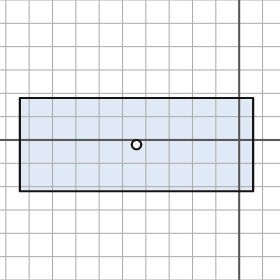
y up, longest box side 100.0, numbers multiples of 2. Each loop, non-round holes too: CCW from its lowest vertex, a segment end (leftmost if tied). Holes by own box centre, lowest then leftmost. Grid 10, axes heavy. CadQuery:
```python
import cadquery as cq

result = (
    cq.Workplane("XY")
    .moveTo(-94.0, -22.0)
    .lineTo(6.0, -22.0)
    .lineTo(6.0, 18.0)
    .lineTo(-94.0, 18.0)
    .close()
    .moveTo(-44.0, -2.0)
    .circle(2.0)
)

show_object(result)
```